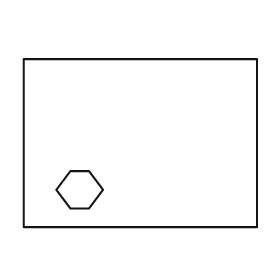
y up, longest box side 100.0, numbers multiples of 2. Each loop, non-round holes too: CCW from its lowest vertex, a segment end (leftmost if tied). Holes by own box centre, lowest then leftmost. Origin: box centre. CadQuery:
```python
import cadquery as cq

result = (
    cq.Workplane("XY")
    .moveTo(-50.0, -36.0)
    .lineTo(50.0, -36.0)
    .lineTo(50.0, 36.0)
    .lineTo(-50.0, 36.0)
    .close()
    .moveTo(-30.0, -28.0)
    .lineTo(-22.0, -28.0)
    .lineTo(-16.0, -20.0)
    .lineTo(-22.0, -12.0)
    .lineTo(-30.0, -12.0)
    .lineTo(-36.0, -20.0)
    .close()
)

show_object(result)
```